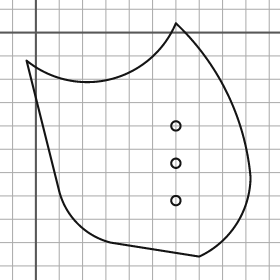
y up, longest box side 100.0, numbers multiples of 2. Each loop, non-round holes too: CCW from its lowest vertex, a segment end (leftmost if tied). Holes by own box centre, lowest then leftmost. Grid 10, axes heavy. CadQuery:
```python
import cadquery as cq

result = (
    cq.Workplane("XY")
    .moveTo(70.0, -96.0)
    .threePointArc((86.0, -82.0), (92.0, -62.0))
    .threePointArc((82.0, -26.0), (60.0, 4.0))
    .threePointArc((32.0, -20.0), (-4.0, -12.0))
    .lineTo(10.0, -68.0)
    .threePointArc((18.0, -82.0), (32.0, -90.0))
    .close()
    .moveTo(60.0, -72.0)
    .circle(2.0)
    .moveTo(60.0, -56.0)
    .circle(2.0)
    .moveTo(60.0, -40.0)
    .circle(2.0)
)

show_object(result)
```